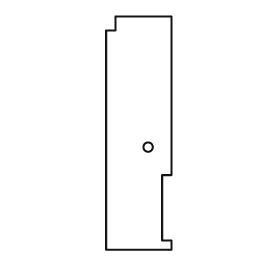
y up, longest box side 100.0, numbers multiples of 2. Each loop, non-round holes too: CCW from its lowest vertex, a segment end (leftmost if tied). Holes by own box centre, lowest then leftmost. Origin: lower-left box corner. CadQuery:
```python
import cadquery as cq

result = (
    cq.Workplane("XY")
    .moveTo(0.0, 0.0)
    .lineTo(28.0, 0.0)
    .lineTo(28.0, 4.0)
    .lineTo(24.0, 4.0)
    .lineTo(24.0, 32.0)
    .lineTo(28.0, 32.0)
    .lineTo(28.0, 100.0)
    .lineTo(4.0, 100.0)
    .lineTo(4.0, 94.0)
    .lineTo(0.0, 94.0)
    .close()
    .moveTo(18.0, 44.0)
    .circle(2.0)
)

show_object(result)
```